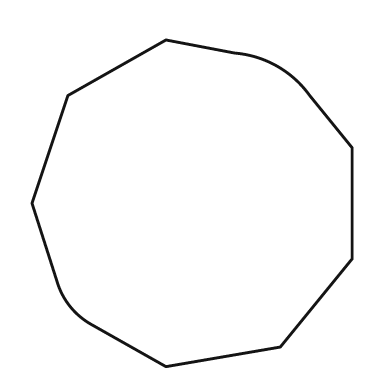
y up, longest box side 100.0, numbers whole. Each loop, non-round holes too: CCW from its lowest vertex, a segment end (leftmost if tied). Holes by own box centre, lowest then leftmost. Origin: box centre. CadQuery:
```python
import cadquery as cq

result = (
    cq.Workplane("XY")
    .moveTo(-8.0, -50.0)
    .lineTo(27.0, -44.0)
    .lineTo(49.0, -17.0)
    .lineTo(49.0, 17.0)
    .lineTo(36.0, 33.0)
    .threePointArc((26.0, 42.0), (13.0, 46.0))
    .lineTo(-8.0, 50.0)
    .lineTo(-38.0, 33.0)
    .lineTo(-49.0, 0.0)
    .lineTo(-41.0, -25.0)
    .threePointArc((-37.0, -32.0), (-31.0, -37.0))
    .close()
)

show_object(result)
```